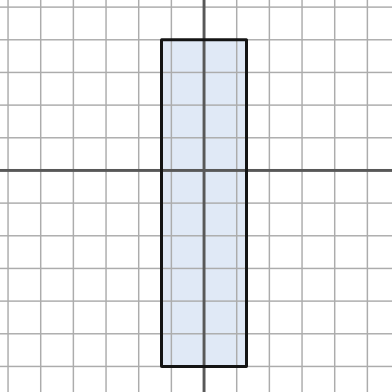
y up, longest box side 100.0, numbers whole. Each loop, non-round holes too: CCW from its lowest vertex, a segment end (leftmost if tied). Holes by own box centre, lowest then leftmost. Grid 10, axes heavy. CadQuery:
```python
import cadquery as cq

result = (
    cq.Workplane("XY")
    .moveTo(-13.0, -60.0)
    .lineTo(13.0, -60.0)
    .lineTo(13.0, 40.0)
    .lineTo(-13.0, 40.0)
    .close()
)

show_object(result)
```